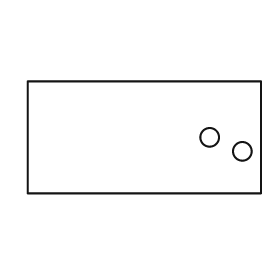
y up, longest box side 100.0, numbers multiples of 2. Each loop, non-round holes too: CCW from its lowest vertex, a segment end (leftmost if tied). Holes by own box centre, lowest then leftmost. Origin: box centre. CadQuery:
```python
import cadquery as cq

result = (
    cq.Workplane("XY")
    .moveTo(-50.0, -24.0)
    .lineTo(50.0, -24.0)
    .lineTo(50.0, 24.0)
    .lineTo(-50.0, 24.0)
    .close()
    .moveTo(42.0, -6.0)
    .circle(4.0)
    .moveTo(28.0, 0.0)
    .circle(4.0)
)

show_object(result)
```